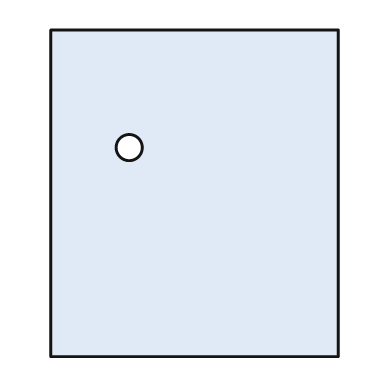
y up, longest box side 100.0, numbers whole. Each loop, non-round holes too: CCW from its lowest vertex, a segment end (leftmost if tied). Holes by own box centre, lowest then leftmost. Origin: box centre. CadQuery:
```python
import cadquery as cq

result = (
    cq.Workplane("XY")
    .moveTo(-44.0, -50.0)
    .lineTo(44.0, -50.0)
    .lineTo(44.0, 50.0)
    .lineTo(-44.0, 50.0)
    .close()
    .moveTo(-20.0, 14.0)
    .circle(4.0)
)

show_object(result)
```